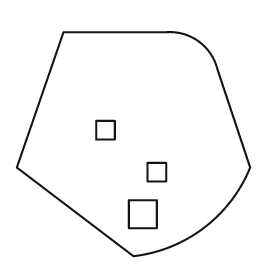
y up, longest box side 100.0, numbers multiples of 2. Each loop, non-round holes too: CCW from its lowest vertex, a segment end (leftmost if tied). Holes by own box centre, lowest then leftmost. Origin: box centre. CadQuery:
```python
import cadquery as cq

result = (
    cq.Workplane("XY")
    .moveTo(0.0, -48.0)
    .threePointArc((30.0, -36.0), (50.0, -10.0))
    .lineTo(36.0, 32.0)
    .threePointArc((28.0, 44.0), (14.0, 48.0))
    .lineTo(-30.0, 48.0)
    .lineTo(-50.0, -10.0)
    .close()
    .moveTo(-2.0, -36.0)
    .lineTo(10.0, -36.0)
    .lineTo(10.0, -24.0)
    .lineTo(-2.0, -24.0)
    .close()
    .moveTo(6.0, -16.0)
    .lineTo(14.0, -16.0)
    .lineTo(14.0, -8.0)
    .lineTo(6.0, -8.0)
    .close()
    .moveTo(-16.0, 2.0)
    .lineTo(-8.0, 2.0)
    .lineTo(-8.0, 10.0)
    .lineTo(-16.0, 10.0)
    .close()
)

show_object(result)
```